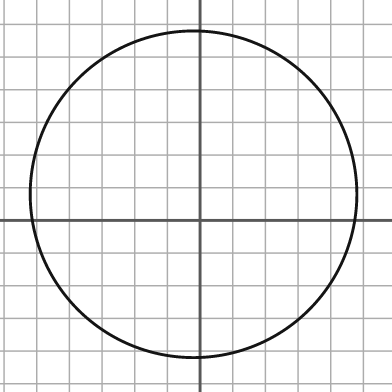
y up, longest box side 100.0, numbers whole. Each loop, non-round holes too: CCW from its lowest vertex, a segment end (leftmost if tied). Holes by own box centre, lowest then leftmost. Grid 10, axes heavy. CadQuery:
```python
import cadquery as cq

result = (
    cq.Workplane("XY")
    .moveTo(-2.0, 8.0)
    .circle(50.0)
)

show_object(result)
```